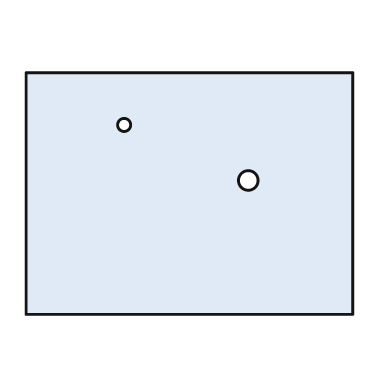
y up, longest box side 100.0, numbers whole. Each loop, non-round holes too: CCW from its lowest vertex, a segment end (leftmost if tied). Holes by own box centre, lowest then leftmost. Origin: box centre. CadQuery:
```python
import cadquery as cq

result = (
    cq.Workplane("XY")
    .moveTo(-50.0, -37.0)
    .lineTo(50.0, -37.0)
    .lineTo(50.0, 37.0)
    .lineTo(-50.0, 37.0)
    .close()
    .moveTo(18.0, 4.0)
    .circle(3.0)
    .moveTo(-20.0, 21.0)
    .circle(2.0)
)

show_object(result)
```